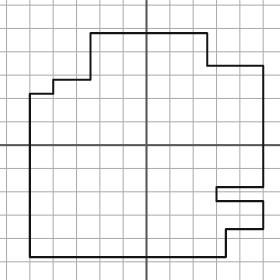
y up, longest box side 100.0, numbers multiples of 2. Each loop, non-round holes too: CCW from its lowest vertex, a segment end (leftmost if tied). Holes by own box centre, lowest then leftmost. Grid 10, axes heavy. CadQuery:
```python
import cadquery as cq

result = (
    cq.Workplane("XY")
    .moveTo(-50.0, -48.0)
    .lineTo(34.0, -48.0)
    .lineTo(34.0, -36.0)
    .lineTo(50.0, -36.0)
    .lineTo(50.0, -24.0)
    .lineTo(30.0, -24.0)
    .lineTo(30.0, -18.0)
    .lineTo(50.0, -18.0)
    .lineTo(50.0, 34.0)
    .lineTo(26.0, 34.0)
    .lineTo(26.0, 48.0)
    .lineTo(-24.0, 48.0)
    .lineTo(-24.0, 28.0)
    .lineTo(-40.0, 28.0)
    .lineTo(-40.0, 22.0)
    .lineTo(-50.0, 22.0)
    .close()
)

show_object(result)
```